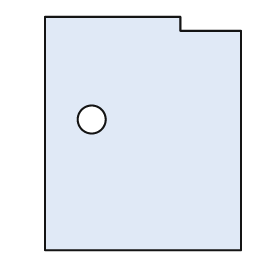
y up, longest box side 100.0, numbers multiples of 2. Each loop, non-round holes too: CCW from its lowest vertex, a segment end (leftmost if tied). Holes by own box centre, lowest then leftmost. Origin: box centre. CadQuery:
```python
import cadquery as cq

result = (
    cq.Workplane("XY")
    .moveTo(-42.0, -50.0)
    .lineTo(42.0, -50.0)
    .lineTo(42.0, 44.0)
    .lineTo(16.0, 44.0)
    .lineTo(16.0, 50.0)
    .lineTo(-42.0, 50.0)
    .close()
    .moveTo(-22.0, 6.0)
    .circle(6.0)
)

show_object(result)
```